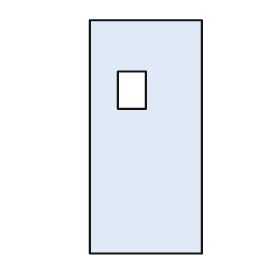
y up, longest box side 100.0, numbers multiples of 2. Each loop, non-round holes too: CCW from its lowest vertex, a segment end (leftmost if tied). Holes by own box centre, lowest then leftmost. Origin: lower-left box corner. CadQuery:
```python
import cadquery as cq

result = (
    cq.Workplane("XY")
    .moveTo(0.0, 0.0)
    .lineTo(48.0, 0.0)
    .lineTo(48.0, 100.0)
    .lineTo(0.0, 100.0)
    .close()
    .moveTo(12.0, 62.0)
    .lineTo(24.0, 62.0)
    .lineTo(24.0, 78.0)
    .lineTo(12.0, 78.0)
    .close()
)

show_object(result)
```